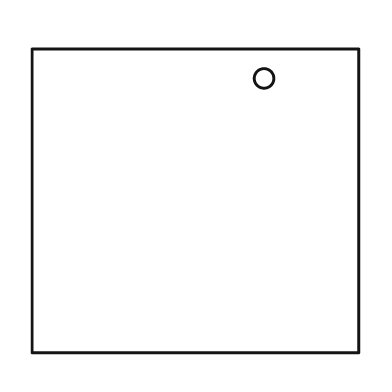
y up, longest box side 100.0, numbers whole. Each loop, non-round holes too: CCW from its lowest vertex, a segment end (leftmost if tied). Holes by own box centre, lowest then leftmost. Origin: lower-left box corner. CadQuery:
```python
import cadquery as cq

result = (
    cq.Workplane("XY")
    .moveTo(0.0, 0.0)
    .lineTo(100.0, 0.0)
    .lineTo(100.0, 93.0)
    .lineTo(0.0, 93.0)
    .close()
    .moveTo(71.0, 84.0)
    .circle(3.0)
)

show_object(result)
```